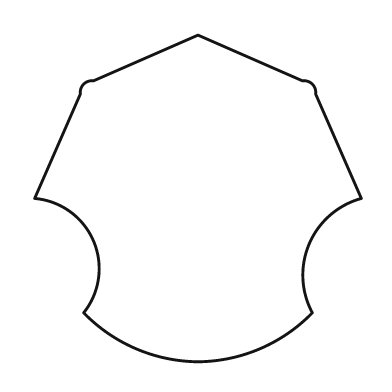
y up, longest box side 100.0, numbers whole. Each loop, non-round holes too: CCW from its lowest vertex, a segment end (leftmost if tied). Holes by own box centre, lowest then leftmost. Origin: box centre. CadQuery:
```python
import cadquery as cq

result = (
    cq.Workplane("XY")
    .moveTo(0.0, -50.0)
    .threePointArc((19.0, -46.0), (35.0, -35.0))
    .threePointArc((34.0, -14.0), (50.0, 0.0))
    .lineTo(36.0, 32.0)
    .threePointArc((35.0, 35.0), (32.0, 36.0))
    .lineTo(0.0, 50.0)
    .lineTo(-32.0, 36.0)
    .threePointArc((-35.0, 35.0), (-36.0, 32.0))
    .lineTo(-50.0, 0.0)
    .threePointArc((-32.0, -13.0), (-35.0, -35.0))
    .threePointArc((-19.0, -46.0), (0.0, -50.0))
    .close()
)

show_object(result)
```